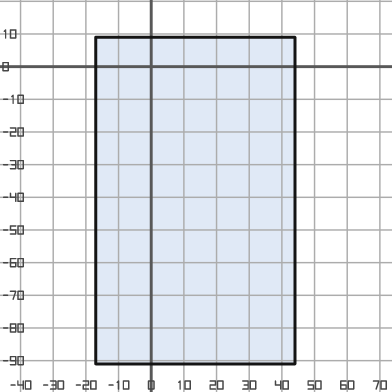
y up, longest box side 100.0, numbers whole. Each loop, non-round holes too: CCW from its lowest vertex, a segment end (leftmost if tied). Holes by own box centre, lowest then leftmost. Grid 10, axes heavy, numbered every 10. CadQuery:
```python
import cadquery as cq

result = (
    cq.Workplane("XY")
    .moveTo(-17.0, -91.0)
    .lineTo(44.0, -91.0)
    .lineTo(44.0, 9.0)
    .lineTo(-17.0, 9.0)
    .close()
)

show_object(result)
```